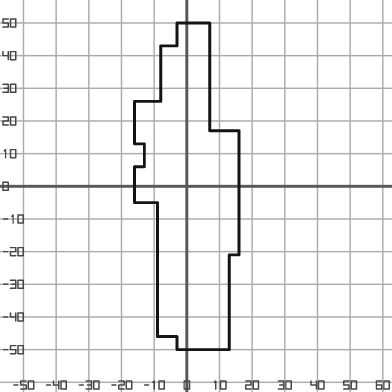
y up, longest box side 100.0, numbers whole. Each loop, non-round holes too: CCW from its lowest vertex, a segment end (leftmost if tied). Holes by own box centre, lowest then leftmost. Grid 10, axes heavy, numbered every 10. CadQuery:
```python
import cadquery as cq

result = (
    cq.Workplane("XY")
    .moveTo(-3.0, -50.0)
    .lineTo(13.0, -50.0)
    .lineTo(13.0, -21.0)
    .lineTo(16.0, -21.0)
    .lineTo(16.0, 17.0)
    .lineTo(7.0, 17.0)
    .lineTo(7.0, 50.0)
    .lineTo(-3.0, 50.0)
    .lineTo(-3.0, 43.0)
    .lineTo(-8.0, 43.0)
    .lineTo(-8.0, 26.0)
    .lineTo(-16.0, 26.0)
    .lineTo(-16.0, 13.0)
    .lineTo(-13.0, 13.0)
    .lineTo(-13.0, 6.0)
    .lineTo(-16.0, 6.0)
    .lineTo(-16.0, -5.0)
    .lineTo(-9.0, -5.0)
    .lineTo(-9.0, -46.0)
    .lineTo(-3.0, -46.0)
    .close()
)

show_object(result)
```